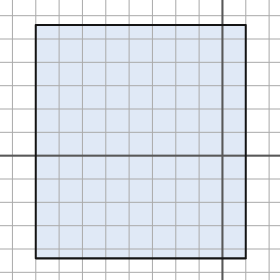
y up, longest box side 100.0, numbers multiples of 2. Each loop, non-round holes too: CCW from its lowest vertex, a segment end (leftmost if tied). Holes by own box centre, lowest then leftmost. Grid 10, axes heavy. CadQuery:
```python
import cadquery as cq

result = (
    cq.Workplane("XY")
    .moveTo(-80.0, -44.0)
    .lineTo(10.0, -44.0)
    .lineTo(10.0, 56.0)
    .lineTo(-80.0, 56.0)
    .close()
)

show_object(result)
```